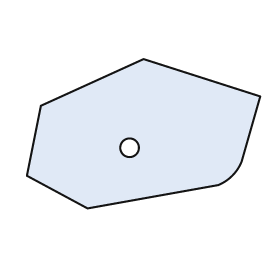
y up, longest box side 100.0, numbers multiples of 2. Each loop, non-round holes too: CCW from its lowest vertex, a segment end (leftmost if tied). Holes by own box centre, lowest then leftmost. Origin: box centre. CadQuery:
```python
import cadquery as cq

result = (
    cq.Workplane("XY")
    .moveTo(-24.0, -32.0)
    .lineTo(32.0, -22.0)
    .threePointArc((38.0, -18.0), (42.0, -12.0))
    .lineTo(50.0, 16.0)
    .lineTo(0.0, 32.0)
    .lineTo(-44.0, 12.0)
    .lineTo(-50.0, -18.0)
    .close()
    .moveTo(-6.0, -6.0)
    .circle(4.0)
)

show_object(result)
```